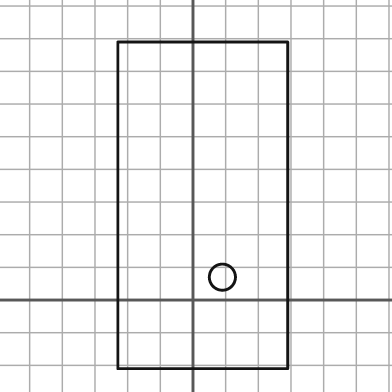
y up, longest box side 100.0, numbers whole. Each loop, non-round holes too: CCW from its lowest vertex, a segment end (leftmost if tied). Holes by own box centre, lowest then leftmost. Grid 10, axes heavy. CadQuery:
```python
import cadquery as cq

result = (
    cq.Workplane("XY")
    .moveTo(-23.0, -21.0)
    .lineTo(29.0, -21.0)
    .lineTo(29.0, 79.0)
    .lineTo(-23.0, 79.0)
    .close()
    .moveTo(9.0, 7.0)
    .circle(4.0)
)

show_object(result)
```